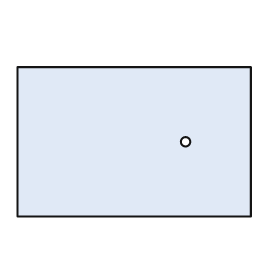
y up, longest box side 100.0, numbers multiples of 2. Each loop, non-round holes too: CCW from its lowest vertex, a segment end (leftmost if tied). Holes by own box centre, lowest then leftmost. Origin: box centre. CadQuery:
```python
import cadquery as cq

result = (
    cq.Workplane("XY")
    .moveTo(-50.0, -32.0)
    .lineTo(50.0, -32.0)
    .lineTo(50.0, 32.0)
    .lineTo(-50.0, 32.0)
    .close()
    .moveTo(22.0, 0.0)
    .circle(2.0)
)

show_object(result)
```